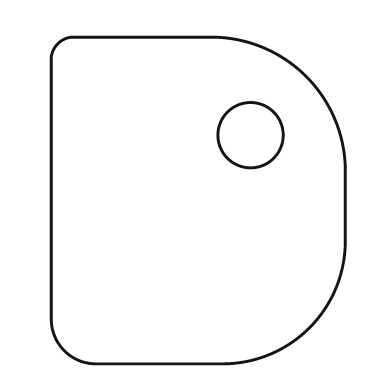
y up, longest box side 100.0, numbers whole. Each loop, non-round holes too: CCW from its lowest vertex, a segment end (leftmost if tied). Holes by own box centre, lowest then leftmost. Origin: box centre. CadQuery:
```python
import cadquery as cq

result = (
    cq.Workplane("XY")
    .moveTo(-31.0, -50.0)
    .lineTo(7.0, -50.0)
    .threePointArc((34.0, -39.0), (45.0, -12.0))
    .lineTo(45.0, 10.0)
    .threePointArc((33.0, 38.0), (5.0, 50.0))
    .lineTo(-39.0, 50.0)
    .threePointArc((-43.0, 48.0), (-45.0, 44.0))
    .lineTo(-45.0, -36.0)
    .threePointArc((-41.0, -46.0), (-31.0, -50.0))
    .close()
    .moveTo(16.0, 20.0)
    .circle(10.0)
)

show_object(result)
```